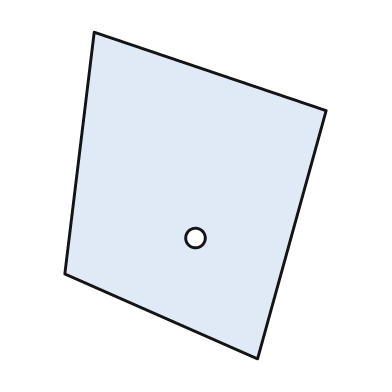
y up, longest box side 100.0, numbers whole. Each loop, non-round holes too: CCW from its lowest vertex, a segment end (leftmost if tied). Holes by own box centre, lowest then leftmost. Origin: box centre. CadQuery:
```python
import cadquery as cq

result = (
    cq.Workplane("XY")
    .moveTo(19.0, -50.0)
    .lineTo(40.0, 26.0)
    .lineTo(-31.0, 50.0)
    .lineTo(-40.0, -24.0)
    .close()
    .moveTo(0.0, -13.0)
    .circle(3.0)
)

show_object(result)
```